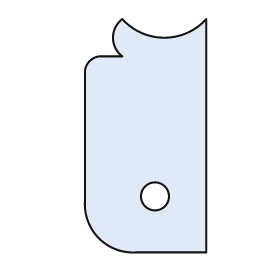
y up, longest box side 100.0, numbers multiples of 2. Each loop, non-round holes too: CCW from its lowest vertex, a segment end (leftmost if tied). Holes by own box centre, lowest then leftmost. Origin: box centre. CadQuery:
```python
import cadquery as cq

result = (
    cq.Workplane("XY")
    .moveTo(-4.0, -50.0)
    .lineTo(26.0, -50.0)
    .lineTo(26.0, 50.0)
    .threePointArc((8.0, 42.0), (-10.0, 50.0))
    .threePointArc((-14.0, 42.0), (-10.0, 34.0))
    .lineTo(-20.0, 34.0)
    .threePointArc((-24.0, 32.0), (-26.0, 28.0))
    .lineTo(-26.0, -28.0)
    .threePointArc((-20.0, -44.0), (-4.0, -50.0))
    .close()
    .moveTo(4.0, -26.0)
    .circle(6.0)
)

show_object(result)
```